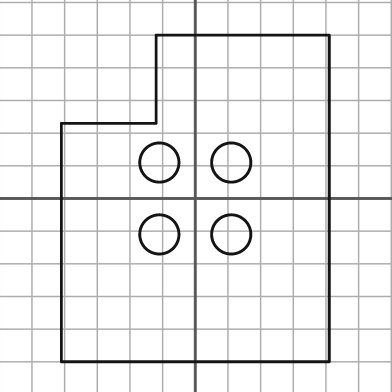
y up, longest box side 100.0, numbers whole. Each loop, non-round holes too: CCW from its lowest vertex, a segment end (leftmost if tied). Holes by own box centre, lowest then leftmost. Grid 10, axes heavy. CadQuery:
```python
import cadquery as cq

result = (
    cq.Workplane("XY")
    .moveTo(-41.0, -50.0)
    .lineTo(41.0, -50.0)
    .lineTo(41.0, 50.0)
    .lineTo(-12.0, 50.0)
    .lineTo(-12.0, 23.0)
    .lineTo(-41.0, 23.0)
    .close()
    .moveTo(-11.0, -11.0)
    .circle(6.0)
    .moveTo(11.0, -11.0)
    .circle(6.0)
    .moveTo(-11.0, 11.0)
    .circle(6.0)
    .moveTo(11.0, 11.0)
    .circle(6.0)
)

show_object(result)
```